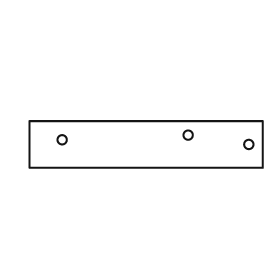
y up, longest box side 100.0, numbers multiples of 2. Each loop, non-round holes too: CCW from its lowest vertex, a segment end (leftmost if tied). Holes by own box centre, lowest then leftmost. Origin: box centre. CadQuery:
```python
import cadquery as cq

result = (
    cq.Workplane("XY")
    .moveTo(-50.0, -10.0)
    .lineTo(50.0, -10.0)
    .lineTo(50.0, 10.0)
    .lineTo(-50.0, 10.0)
    .close()
    .moveTo(44.0, 0.0)
    .circle(2.0)
    .moveTo(-36.0, 2.0)
    .circle(2.0)
    .moveTo(18.0, 4.0)
    .circle(2.0)
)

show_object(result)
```